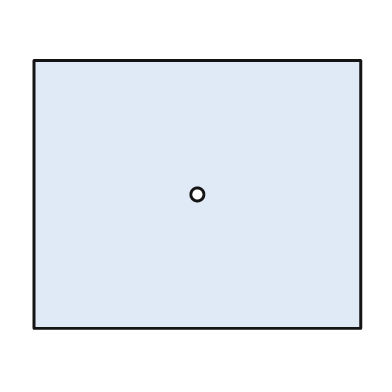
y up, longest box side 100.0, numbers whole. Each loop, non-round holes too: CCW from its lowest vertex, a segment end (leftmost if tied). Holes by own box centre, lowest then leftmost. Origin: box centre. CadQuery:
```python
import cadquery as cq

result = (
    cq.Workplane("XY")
    .moveTo(-50.0, -41.0)
    .lineTo(50.0, -41.0)
    .lineTo(50.0, 41.0)
    .lineTo(-50.0, 41.0)
    .close()
    .moveTo(0.0, 0.0)
    .circle(2.0)
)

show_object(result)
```